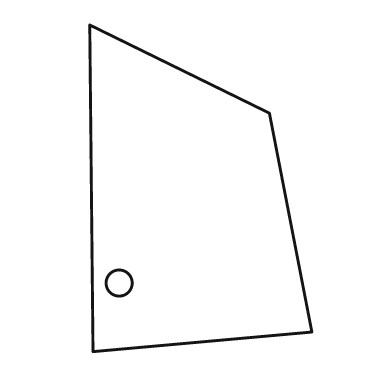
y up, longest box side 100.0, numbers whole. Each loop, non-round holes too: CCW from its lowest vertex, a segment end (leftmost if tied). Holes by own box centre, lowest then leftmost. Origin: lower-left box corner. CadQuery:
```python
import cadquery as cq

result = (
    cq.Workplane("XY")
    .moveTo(1.0, 0.0)
    .lineTo(68.0, 6.0)
    .lineTo(55.0, 73.0)
    .lineTo(0.0, 100.0)
    .close()
    .moveTo(9.0, 21.0)
    .circle(4.0)
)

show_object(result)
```